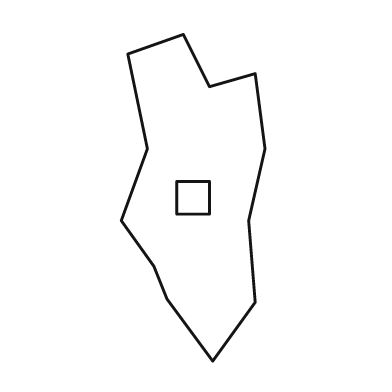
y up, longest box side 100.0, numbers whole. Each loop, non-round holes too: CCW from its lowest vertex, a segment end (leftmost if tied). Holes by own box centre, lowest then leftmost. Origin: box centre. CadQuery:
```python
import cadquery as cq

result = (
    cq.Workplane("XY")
    .moveTo(6.0, -50.0)
    .lineTo(19.0, -32.0)
    .lineTo(17.0, -7.0)
    .lineTo(22.0, 15.0)
    .lineTo(19.0, 38.0)
    .lineTo(5.0, 34.0)
    .lineTo(-3.0, 50.0)
    .lineTo(-20.0, 44.0)
    .lineTo(-14.0, 15.0)
    .lineTo(-22.0, -7.0)
    .lineTo(-12.0, -21.0)
    .lineTo(-8.0, -31.0)
    .close()
    .moveTo(-5.0, -5.0)
    .lineTo(5.0, -5.0)
    .lineTo(5.0, 5.0)
    .lineTo(-5.0, 5.0)
    .close()
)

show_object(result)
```